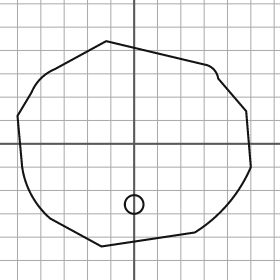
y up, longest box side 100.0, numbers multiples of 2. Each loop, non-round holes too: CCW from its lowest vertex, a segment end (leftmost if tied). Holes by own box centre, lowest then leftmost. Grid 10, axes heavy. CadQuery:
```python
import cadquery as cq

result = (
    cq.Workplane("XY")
    .moveTo(-14.0, -44.0)
    .lineTo(26.0, -38.0)
    .threePointArc((40.0, -26.0), (50.0, -10.0))
    .lineTo(48.0, 14.0)
    .lineTo(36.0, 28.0)
    .threePointArc((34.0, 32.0), (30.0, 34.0))
    .lineTo(-12.0, 44.0)
    .lineTo(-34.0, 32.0)
    .threePointArc((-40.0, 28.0), (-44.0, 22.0))
    .lineTo(-50.0, 12.0)
    .lineTo(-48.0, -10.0)
    .threePointArc((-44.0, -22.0), (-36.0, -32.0))
    .close()
    .moveTo(0.0, -26.0)
    .circle(4.0)
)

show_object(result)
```